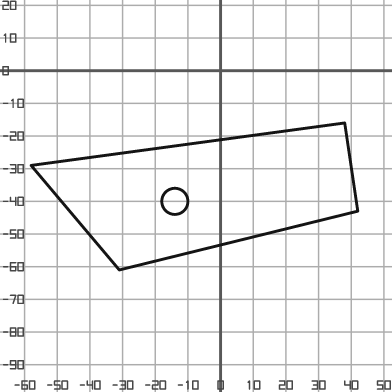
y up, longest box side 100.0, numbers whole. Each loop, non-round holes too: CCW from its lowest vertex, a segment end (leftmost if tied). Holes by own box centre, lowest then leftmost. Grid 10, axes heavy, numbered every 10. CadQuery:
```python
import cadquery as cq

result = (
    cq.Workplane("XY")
    .moveTo(-31.0, -61.0)
    .lineTo(42.0, -43.0)
    .lineTo(38.0, -16.0)
    .lineTo(-58.0, -29.0)
    .close()
    .moveTo(-14.0, -40.0)
    .circle(4.0)
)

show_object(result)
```